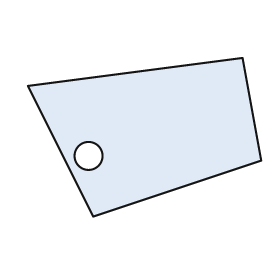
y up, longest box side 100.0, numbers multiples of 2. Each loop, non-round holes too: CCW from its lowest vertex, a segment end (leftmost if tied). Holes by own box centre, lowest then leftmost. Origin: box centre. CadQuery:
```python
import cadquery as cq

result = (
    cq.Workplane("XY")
    .moveTo(-22.0, -34.0)
    .lineTo(50.0, -10.0)
    .lineTo(42.0, 34.0)
    .lineTo(-50.0, 22.0)
    .close()
    .moveTo(-24.0, -8.0)
    .circle(6.0)
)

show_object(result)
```